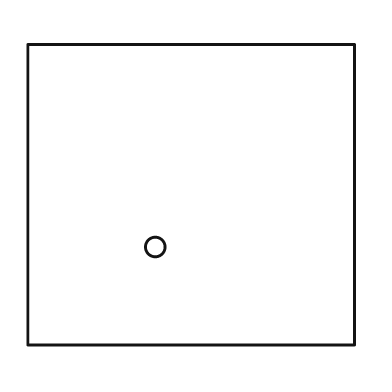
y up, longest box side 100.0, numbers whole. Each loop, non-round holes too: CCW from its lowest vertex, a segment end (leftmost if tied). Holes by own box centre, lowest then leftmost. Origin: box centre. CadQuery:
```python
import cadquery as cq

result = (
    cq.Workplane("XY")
    .moveTo(-50.0, -46.0)
    .lineTo(50.0, -46.0)
    .lineTo(50.0, 46.0)
    .lineTo(-50.0, 46.0)
    .close()
    .moveTo(-11.0, -16.0)
    .circle(3.0)
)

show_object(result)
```